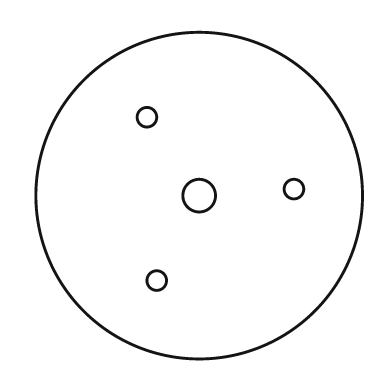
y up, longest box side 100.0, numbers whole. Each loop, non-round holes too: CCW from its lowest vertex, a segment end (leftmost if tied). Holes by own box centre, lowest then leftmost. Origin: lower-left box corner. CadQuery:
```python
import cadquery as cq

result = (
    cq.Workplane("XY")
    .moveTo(50.0, 50.0)
    .circle(50.0)
    .moveTo(37.0, 24.0)
    .circle(3.0)
    .moveTo(50.0, 50.0)
    .circle(5.0)
    .moveTo(79.0, 52.0)
    .circle(3.0)
    .moveTo(34.0, 74.0)
    .circle(3.0)
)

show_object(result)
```